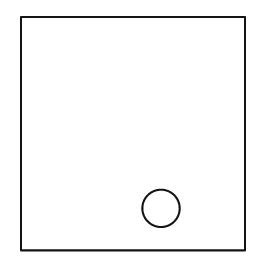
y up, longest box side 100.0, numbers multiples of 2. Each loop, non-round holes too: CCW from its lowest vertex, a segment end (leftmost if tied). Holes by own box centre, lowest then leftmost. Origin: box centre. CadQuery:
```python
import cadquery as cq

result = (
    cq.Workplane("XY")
    .moveTo(-48.0, -50.0)
    .lineTo(48.0, -50.0)
    .lineTo(48.0, 50.0)
    .lineTo(-48.0, 50.0)
    .close()
    .moveTo(12.0, -32.0)
    .circle(8.0)
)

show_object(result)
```